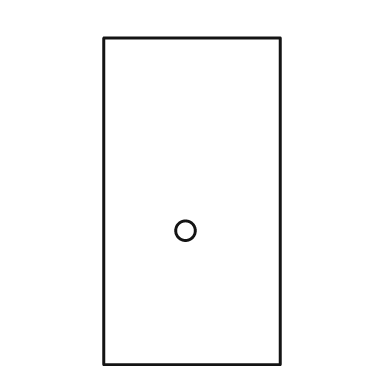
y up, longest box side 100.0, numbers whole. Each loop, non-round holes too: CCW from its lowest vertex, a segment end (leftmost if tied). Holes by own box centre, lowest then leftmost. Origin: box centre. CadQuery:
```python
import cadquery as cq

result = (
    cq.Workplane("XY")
    .moveTo(-27.0, -50.0)
    .lineTo(27.0, -50.0)
    .lineTo(27.0, 50.0)
    .lineTo(-27.0, 50.0)
    .close()
    .moveTo(-2.0, -9.0)
    .circle(3.0)
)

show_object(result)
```